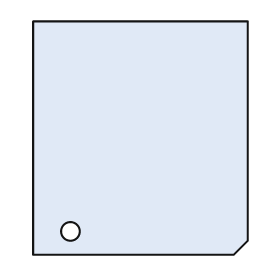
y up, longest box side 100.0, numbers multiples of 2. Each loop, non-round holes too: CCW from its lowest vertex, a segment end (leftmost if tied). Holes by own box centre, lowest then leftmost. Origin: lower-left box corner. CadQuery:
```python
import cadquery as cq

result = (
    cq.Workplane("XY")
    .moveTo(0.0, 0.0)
    .lineTo(86.0, 0.0)
    .lineTo(92.0, 6.0)
    .lineTo(92.0, 100.0)
    .lineTo(0.0, 100.0)
    .close()
    .moveTo(16.0, 10.0)
    .circle(4.0)
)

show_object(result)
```